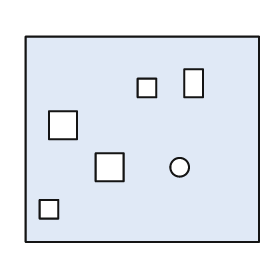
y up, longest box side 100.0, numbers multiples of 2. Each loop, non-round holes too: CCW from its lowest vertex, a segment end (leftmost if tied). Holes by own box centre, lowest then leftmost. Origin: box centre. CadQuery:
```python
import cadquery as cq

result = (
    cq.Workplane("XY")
    .moveTo(-50.0, -44.0)
    .lineTo(50.0, -44.0)
    .lineTo(50.0, 44.0)
    .lineTo(-50.0, 44.0)
    .close()
    .moveTo(-44.0, -34.0)
    .lineTo(-36.0, -34.0)
    .lineTo(-36.0, -26.0)
    .lineTo(-44.0, -26.0)
    .close()
    .moveTo(-20.0, -18.0)
    .lineTo(-8.0, -18.0)
    .lineTo(-8.0, -6.0)
    .lineTo(-20.0, -6.0)
    .close()
    .moveTo(16.0, -12.0)
    .circle(4.0)
    .moveTo(-40.0, 0.0)
    .lineTo(-28.0, 0.0)
    .lineTo(-28.0, 12.0)
    .lineTo(-40.0, 12.0)
    .close()
    .moveTo(-2.0, 18.0)
    .lineTo(6.0, 18.0)
    .lineTo(6.0, 26.0)
    .lineTo(-2.0, 26.0)
    .close()
    .moveTo(18.0, 18.0)
    .lineTo(26.0, 18.0)
    .lineTo(26.0, 30.0)
    .lineTo(18.0, 30.0)
    .close()
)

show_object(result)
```